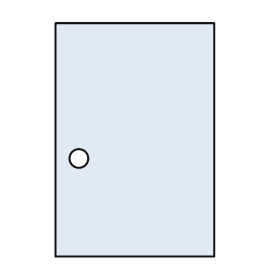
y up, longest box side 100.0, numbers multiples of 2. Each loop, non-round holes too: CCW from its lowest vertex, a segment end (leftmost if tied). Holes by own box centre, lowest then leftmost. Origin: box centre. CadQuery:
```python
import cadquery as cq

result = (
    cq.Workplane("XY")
    .moveTo(-34.0, -50.0)
    .lineTo(34.0, -50.0)
    .lineTo(34.0, 50.0)
    .lineTo(-34.0, 50.0)
    .close()
    .moveTo(-24.0, -8.0)
    .circle(4.0)
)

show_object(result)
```